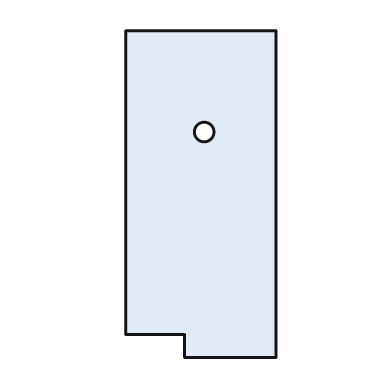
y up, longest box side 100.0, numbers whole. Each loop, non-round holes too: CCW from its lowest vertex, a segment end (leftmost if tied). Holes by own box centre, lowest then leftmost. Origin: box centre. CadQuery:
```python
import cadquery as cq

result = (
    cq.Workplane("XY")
    .moveTo(-5.0, -50.0)
    .lineTo(23.0, -50.0)
    .lineTo(23.0, 50.0)
    .lineTo(-23.0, 50.0)
    .lineTo(-23.0, -43.0)
    .lineTo(-5.0, -43.0)
    .close()
    .moveTo(1.0, 19.0)
    .circle(3.0)
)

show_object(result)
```